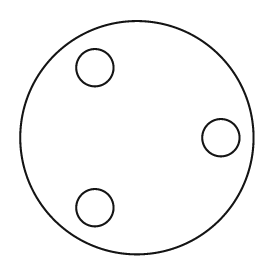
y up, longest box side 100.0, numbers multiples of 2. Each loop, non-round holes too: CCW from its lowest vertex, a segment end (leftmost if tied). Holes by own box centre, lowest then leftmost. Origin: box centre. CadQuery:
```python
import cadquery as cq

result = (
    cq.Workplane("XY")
    .moveTo(0.0, 0.0)
    .circle(50.0)
    .moveTo(-18.0, -30.0)
    .circle(8.0)
    .moveTo(36.0, 0.0)
    .circle(8.0)
    .moveTo(-18.0, 30.0)
    .circle(8.0)
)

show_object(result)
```